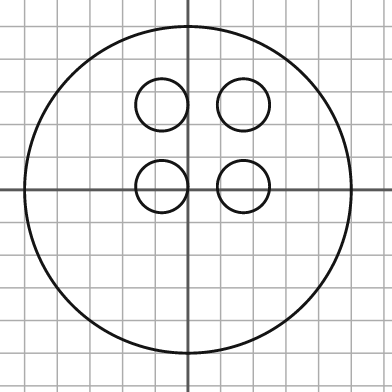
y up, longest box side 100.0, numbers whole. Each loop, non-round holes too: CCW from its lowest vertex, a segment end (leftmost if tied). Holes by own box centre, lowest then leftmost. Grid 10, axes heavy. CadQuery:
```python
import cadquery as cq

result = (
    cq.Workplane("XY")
    .moveTo(0.0, 0.0)
    .circle(50.0)
    .moveTo(-8.0, 1.0)
    .circle(8.0)
    .moveTo(17.0, 1.0)
    .circle(8.0)
    .moveTo(-8.0, 26.0)
    .circle(8.0)
    .moveTo(17.0, 26.0)
    .circle(8.0)
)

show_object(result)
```